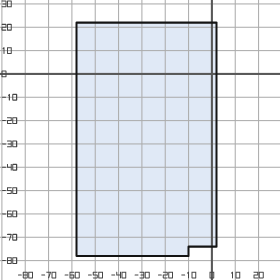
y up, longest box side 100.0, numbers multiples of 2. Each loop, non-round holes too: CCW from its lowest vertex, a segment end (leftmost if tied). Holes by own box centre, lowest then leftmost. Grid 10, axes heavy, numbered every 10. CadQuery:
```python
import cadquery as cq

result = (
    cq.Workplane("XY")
    .moveTo(-58.0, -78.0)
    .lineTo(-10.0, -78.0)
    .lineTo(-10.0, -74.0)
    .lineTo(2.0, -74.0)
    .lineTo(2.0, 22.0)
    .lineTo(-58.0, 22.0)
    .close()
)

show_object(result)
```